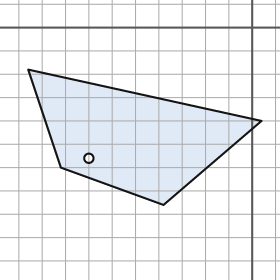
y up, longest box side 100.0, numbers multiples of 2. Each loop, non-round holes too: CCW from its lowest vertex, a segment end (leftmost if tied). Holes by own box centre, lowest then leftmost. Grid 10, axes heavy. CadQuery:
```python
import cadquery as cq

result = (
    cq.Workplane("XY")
    .moveTo(-38.0, -76.0)
    .lineTo(4.0, -40.0)
    .lineTo(-96.0, -18.0)
    .lineTo(-82.0, -60.0)
    .close()
    .moveTo(-70.0, -56.0)
    .circle(2.0)
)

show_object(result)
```